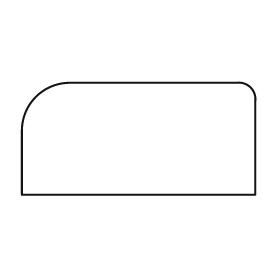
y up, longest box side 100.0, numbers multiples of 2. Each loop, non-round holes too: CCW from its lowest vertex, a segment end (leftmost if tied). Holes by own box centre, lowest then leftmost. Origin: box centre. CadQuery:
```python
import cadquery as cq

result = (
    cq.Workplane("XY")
    .moveTo(-50.0, -24.0)
    .lineTo(50.0, -24.0)
    .lineTo(50.0, 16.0)
    .threePointArc((48.0, 22.0), (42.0, 24.0))
    .lineTo(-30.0, 24.0)
    .threePointArc((-44.0, 18.0), (-50.0, 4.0))
    .close()
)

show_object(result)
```